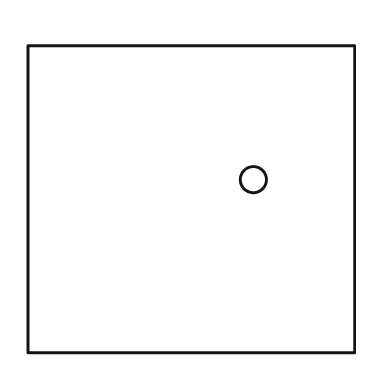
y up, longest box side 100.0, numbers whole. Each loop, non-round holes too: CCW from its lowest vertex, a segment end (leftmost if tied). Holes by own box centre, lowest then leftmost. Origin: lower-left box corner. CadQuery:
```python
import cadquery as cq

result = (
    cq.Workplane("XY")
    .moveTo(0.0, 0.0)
    .lineTo(100.0, 0.0)
    .lineTo(100.0, 94.0)
    .lineTo(0.0, 94.0)
    .close()
    .moveTo(69.0, 53.0)
    .circle(4.0)
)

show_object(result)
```